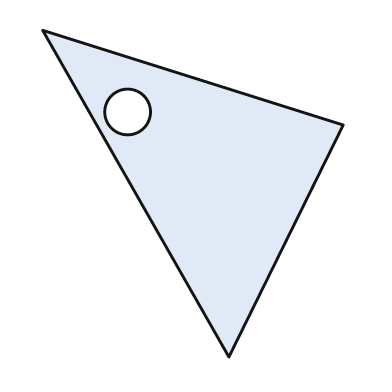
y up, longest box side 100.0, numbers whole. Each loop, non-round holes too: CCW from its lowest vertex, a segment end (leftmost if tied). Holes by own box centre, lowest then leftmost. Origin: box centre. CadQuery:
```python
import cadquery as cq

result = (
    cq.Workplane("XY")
    .moveTo(11.0, -50.0)
    .lineTo(46.0, 21.0)
    .lineTo(-46.0, 50.0)
    .close()
    .moveTo(-20.0, 25.0)
    .circle(7.0)
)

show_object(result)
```